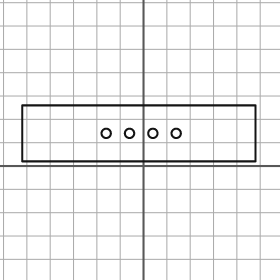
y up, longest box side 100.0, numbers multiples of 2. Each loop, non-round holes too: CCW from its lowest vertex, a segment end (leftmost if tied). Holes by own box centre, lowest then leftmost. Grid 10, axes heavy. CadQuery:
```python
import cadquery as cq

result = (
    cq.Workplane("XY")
    .moveTo(-52.0, 2.0)
    .lineTo(48.0, 2.0)
    .lineTo(48.0, 26.0)
    .lineTo(-52.0, 26.0)
    .close()
    .moveTo(-16.0, 14.0)
    .circle(2.0)
    .moveTo(-6.0, 14.0)
    .circle(2.0)
    .moveTo(4.0, 14.0)
    .circle(2.0)
    .moveTo(14.0, 14.0)
    .circle(2.0)
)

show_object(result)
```